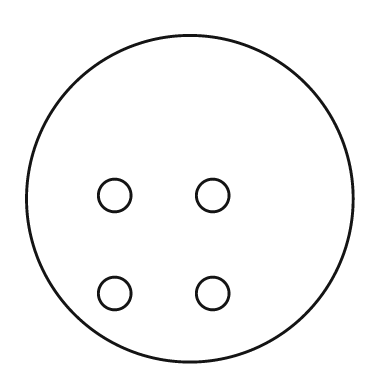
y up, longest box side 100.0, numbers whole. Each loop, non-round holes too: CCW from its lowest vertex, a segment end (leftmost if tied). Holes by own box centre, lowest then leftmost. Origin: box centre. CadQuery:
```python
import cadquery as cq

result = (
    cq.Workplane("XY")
    .moveTo(0.0, 0.0)
    .circle(50.0)
    .moveTo(-23.0, -29.0)
    .circle(5.0)
    .moveTo(7.0, -29.0)
    .circle(5.0)
    .moveTo(-23.0, 1.0)
    .circle(5.0)
    .moveTo(7.0, 1.0)
    .circle(5.0)
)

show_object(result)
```